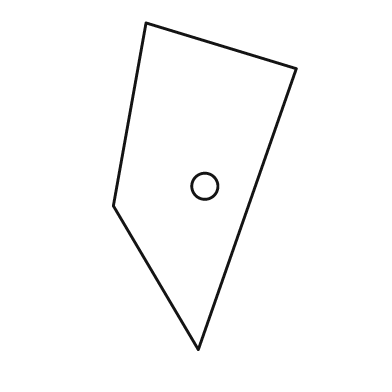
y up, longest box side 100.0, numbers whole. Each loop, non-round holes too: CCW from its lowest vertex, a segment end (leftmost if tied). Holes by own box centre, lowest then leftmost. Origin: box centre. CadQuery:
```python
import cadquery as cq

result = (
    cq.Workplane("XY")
    .moveTo(-2.0, -50.0)
    .lineTo(28.0, 36.0)
    .lineTo(-18.0, 50.0)
    .lineTo(-28.0, -6.0)
    .close()
    .moveTo(0.0, 0.0)
    .circle(4.0)
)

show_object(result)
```